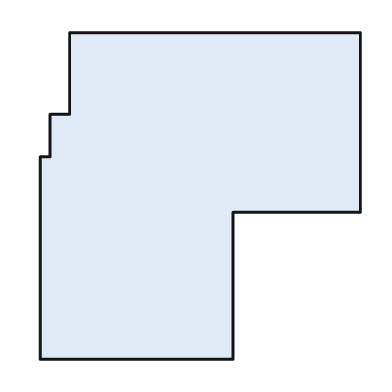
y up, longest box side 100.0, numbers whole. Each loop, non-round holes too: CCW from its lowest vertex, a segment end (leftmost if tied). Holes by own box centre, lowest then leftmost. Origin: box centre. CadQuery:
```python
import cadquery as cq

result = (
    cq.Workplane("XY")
    .moveTo(-49.0, -50.0)
    .lineTo(10.0, -50.0)
    .lineTo(10.0, -5.0)
    .lineTo(49.0, -5.0)
    .lineTo(49.0, 50.0)
    .lineTo(-40.0, 50.0)
    .lineTo(-40.0, 25.0)
    .lineTo(-46.0, 25.0)
    .lineTo(-46.0, 12.0)
    .lineTo(-49.0, 12.0)
    .close()
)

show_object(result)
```